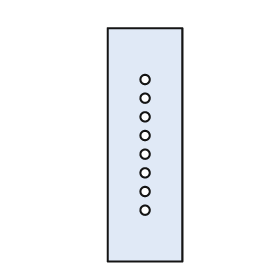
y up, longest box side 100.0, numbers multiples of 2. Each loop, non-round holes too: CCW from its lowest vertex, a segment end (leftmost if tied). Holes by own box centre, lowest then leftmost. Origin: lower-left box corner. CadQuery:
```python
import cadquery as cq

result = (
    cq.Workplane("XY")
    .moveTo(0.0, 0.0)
    .lineTo(32.0, 0.0)
    .lineTo(32.0, 100.0)
    .lineTo(0.0, 100.0)
    .close()
    .moveTo(16.0, 22.0)
    .circle(2.0)
    .moveTo(16.0, 30.0)
    .circle(2.0)
    .moveTo(16.0, 38.0)
    .circle(2.0)
    .moveTo(16.0, 46.0)
    .circle(2.0)
    .moveTo(16.0, 54.0)
    .circle(2.0)
    .moveTo(16.0, 62.0)
    .circle(2.0)
    .moveTo(16.0, 70.0)
    .circle(2.0)
    .moveTo(16.0, 78.0)
    .circle(2.0)
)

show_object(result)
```